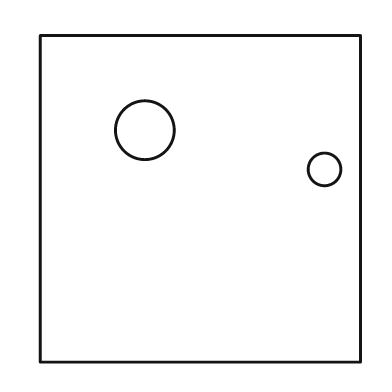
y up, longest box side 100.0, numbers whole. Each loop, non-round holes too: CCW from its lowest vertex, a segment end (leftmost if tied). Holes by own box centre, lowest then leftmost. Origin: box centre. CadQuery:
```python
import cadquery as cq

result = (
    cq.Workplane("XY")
    .moveTo(-49.0, -50.0)
    .lineTo(49.0, -50.0)
    .lineTo(49.0, 50.0)
    .lineTo(-49.0, 50.0)
    .close()
    .moveTo(38.0, 9.0)
    .circle(5.0)
    .moveTo(-17.0, 21.0)
    .circle(9.0)
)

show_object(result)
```